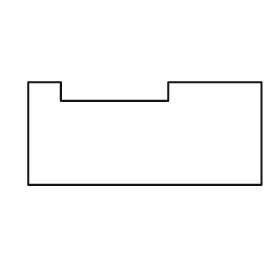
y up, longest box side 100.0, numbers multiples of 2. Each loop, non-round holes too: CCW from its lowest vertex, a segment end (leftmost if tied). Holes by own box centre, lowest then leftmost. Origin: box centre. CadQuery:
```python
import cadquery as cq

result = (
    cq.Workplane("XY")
    .moveTo(-50.0, -22.0)
    .lineTo(50.0, -22.0)
    .lineTo(50.0, 22.0)
    .lineTo(10.0, 22.0)
    .lineTo(10.0, 14.0)
    .lineTo(-36.0, 14.0)
    .lineTo(-36.0, 22.0)
    .lineTo(-50.0, 22.0)
    .close()
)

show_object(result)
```